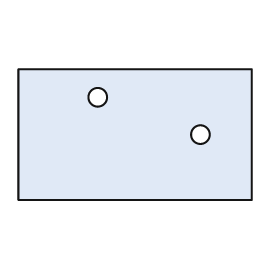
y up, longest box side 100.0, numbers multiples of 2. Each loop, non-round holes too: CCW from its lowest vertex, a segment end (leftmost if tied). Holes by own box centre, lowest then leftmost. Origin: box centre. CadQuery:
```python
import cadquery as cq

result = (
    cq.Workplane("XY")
    .moveTo(-50.0, -28.0)
    .lineTo(50.0, -28.0)
    .lineTo(50.0, 28.0)
    .lineTo(-50.0, 28.0)
    .close()
    .moveTo(28.0, 0.0)
    .circle(4.0)
    .moveTo(-16.0, 16.0)
    .circle(4.0)
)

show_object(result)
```